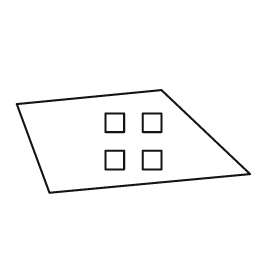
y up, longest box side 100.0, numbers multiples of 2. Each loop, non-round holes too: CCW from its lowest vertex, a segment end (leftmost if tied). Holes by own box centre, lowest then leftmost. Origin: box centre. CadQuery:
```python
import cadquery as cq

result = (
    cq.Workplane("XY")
    .moveTo(-36.0, -22.0)
    .lineTo(50.0, -14.0)
    .lineTo(12.0, 22.0)
    .lineTo(-50.0, 16.0)
    .close()
    .moveTo(-12.0, -12.0)
    .lineTo(-4.0, -12.0)
    .lineTo(-4.0, -4.0)
    .lineTo(-12.0, -4.0)
    .close()
    .moveTo(4.0, -12.0)
    .lineTo(12.0, -12.0)
    .lineTo(12.0, -4.0)
    .lineTo(4.0, -4.0)
    .close()
    .moveTo(-12.0, 4.0)
    .lineTo(-4.0, 4.0)
    .lineTo(-4.0, 12.0)
    .lineTo(-12.0, 12.0)
    .close()
    .moveTo(4.0, 4.0)
    .lineTo(12.0, 4.0)
    .lineTo(12.0, 12.0)
    .lineTo(4.0, 12.0)
    .close()
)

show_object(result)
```